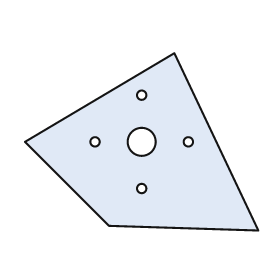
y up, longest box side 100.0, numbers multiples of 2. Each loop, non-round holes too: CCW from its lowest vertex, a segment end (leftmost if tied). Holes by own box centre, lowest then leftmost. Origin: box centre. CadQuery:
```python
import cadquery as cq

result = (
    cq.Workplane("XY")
    .moveTo(50.0, -38.0)
    .lineTo(14.0, 38.0)
    .lineTo(-50.0, 0.0)
    .lineTo(-14.0, -36.0)
    .close()
    .moveTo(0.0, -20.0)
    .circle(2.0)
    .moveTo(-20.0, 0.0)
    .circle(2.0)
    .moveTo(0.0, 0.0)
    .circle(6.0)
    .moveTo(20.0, 0.0)
    .circle(2.0)
    .moveTo(0.0, 20.0)
    .circle(2.0)
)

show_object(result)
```